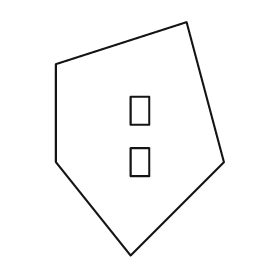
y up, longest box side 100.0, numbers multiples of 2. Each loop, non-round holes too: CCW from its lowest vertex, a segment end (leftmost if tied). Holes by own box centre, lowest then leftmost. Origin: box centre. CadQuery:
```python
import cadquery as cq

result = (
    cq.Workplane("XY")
    .moveTo(-4.0, -50.0)
    .lineTo(36.0, -10.0)
    .lineTo(20.0, 50.0)
    .lineTo(-36.0, 32.0)
    .lineTo(-36.0, -10.0)
    .close()
    .moveTo(-4.0, -16.0)
    .lineTo(4.0, -16.0)
    .lineTo(4.0, -4.0)
    .lineTo(-4.0, -4.0)
    .close()
    .moveTo(-4.0, 6.0)
    .lineTo(4.0, 6.0)
    .lineTo(4.0, 18.0)
    .lineTo(-4.0, 18.0)
    .close()
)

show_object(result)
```